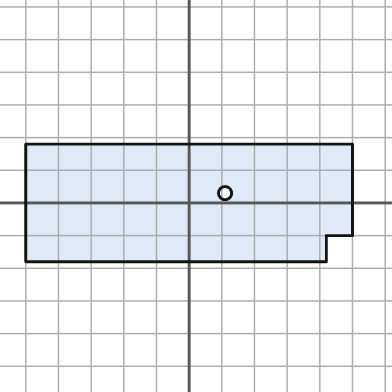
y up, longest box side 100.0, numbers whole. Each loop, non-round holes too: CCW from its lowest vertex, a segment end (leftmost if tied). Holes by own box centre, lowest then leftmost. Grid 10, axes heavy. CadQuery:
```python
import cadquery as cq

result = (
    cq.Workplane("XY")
    .moveTo(-50.0, -18.0)
    .lineTo(42.0, -18.0)
    .lineTo(42.0, -10.0)
    .lineTo(50.0, -10.0)
    .lineTo(50.0, 18.0)
    .lineTo(-50.0, 18.0)
    .close()
    .moveTo(11.0, 3.0)
    .circle(2.0)
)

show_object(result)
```